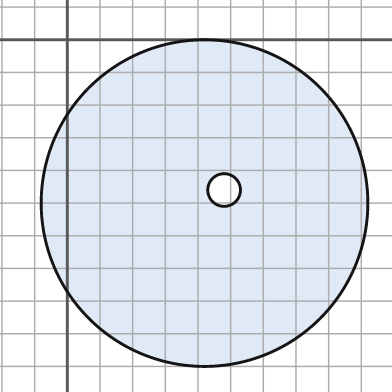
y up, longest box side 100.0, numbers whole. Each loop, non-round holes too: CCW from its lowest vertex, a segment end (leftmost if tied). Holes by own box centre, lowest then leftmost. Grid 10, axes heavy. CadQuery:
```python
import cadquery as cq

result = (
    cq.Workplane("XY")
    .moveTo(42.0, -50.0)
    .circle(50.0)
    .moveTo(48.0, -46.0)
    .circle(5.0)
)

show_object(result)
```